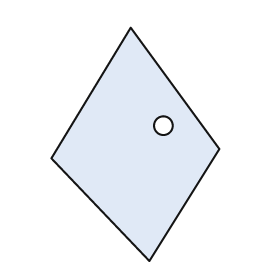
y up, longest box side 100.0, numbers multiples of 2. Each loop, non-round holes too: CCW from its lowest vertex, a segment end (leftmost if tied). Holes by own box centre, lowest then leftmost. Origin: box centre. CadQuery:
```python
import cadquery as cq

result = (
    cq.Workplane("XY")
    .moveTo(6.0, -50.0)
    .lineTo(36.0, -2.0)
    .lineTo(-2.0, 50.0)
    .lineTo(-36.0, -6.0)
    .close()
    .moveTo(12.0, 8.0)
    .circle(4.0)
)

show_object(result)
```